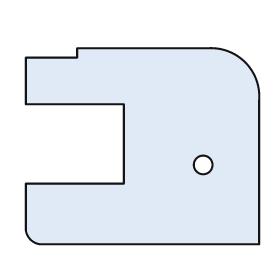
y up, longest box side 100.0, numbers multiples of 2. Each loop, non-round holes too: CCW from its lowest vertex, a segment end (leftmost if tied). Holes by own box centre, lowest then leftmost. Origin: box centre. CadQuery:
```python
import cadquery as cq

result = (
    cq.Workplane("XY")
    .moveTo(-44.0, -42.0)
    .lineTo(50.0, -42.0)
    .lineTo(50.0, 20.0)
    .threePointArc((44.0, 36.0), (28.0, 42.0))
    .lineTo(-28.0, 42.0)
    .lineTo(-28.0, 38.0)
    .lineTo(-50.0, 38.0)
    .lineTo(-50.0, 18.0)
    .lineTo(-8.0, 18.0)
    .lineTo(-8.0, -16.0)
    .lineTo(-50.0, -16.0)
    .lineTo(-50.0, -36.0)
    .threePointArc((-48.0, -40.0), (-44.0, -42.0))
    .close()
    .moveTo(26.0, -8.0)
    .circle(4.0)
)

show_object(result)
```